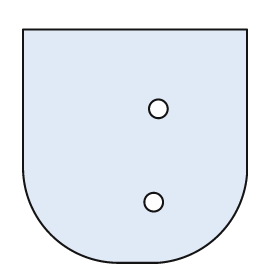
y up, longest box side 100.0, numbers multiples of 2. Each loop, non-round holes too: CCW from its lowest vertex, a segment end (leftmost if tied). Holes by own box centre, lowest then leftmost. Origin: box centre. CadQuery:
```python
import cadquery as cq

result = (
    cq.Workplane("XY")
    .moveTo(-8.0, -50.0)
    .lineTo(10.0, -50.0)
    .threePointArc((36.0, -38.0), (48.0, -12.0))
    .lineTo(48.0, 50.0)
    .lineTo(-48.0, 50.0)
    .lineTo(-48.0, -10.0)
    .threePointArc((-36.0, -38.0), (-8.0, -50.0))
    .close()
    .moveTo(8.0, -24.0)
    .circle(4.0)
    .moveTo(10.0, 16.0)
    .circle(4.0)
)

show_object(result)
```